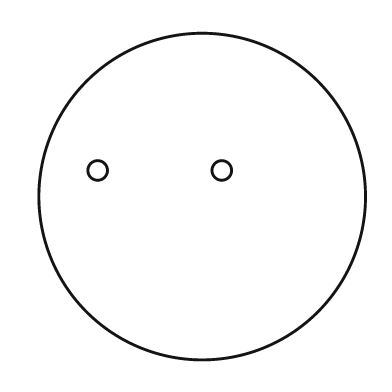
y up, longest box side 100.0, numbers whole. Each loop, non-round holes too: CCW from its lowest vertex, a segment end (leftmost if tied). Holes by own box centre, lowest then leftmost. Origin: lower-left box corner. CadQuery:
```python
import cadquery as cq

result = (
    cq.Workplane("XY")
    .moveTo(50.0, 50.0)
    .circle(50.0)
    .moveTo(18.0, 58.0)
    .circle(3.0)
    .moveTo(56.0, 58.0)
    .circle(3.0)
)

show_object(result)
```